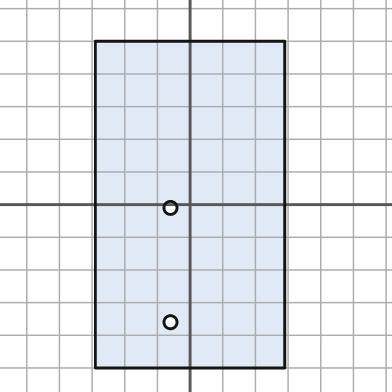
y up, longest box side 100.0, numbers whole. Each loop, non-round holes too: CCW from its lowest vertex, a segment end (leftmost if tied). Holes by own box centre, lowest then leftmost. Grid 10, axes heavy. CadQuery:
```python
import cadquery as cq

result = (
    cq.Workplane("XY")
    .moveTo(-29.0, -50.0)
    .lineTo(29.0, -50.0)
    .lineTo(29.0, 50.0)
    .lineTo(-29.0, 50.0)
    .close()
    .moveTo(-6.0, -36.0)
    .circle(2.0)
    .moveTo(-6.0, -1.0)
    .circle(2.0)
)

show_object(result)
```